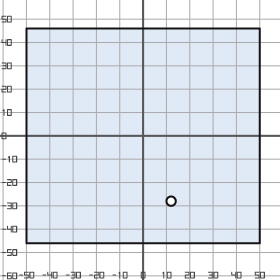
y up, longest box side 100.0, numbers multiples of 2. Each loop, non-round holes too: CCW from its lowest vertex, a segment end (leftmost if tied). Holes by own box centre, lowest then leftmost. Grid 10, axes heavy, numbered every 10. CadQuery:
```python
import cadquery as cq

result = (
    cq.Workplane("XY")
    .moveTo(-50.0, -46.0)
    .lineTo(50.0, -46.0)
    .lineTo(50.0, 46.0)
    .lineTo(-50.0, 46.0)
    .close()
    .moveTo(12.0, -28.0)
    .circle(2.0)
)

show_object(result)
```